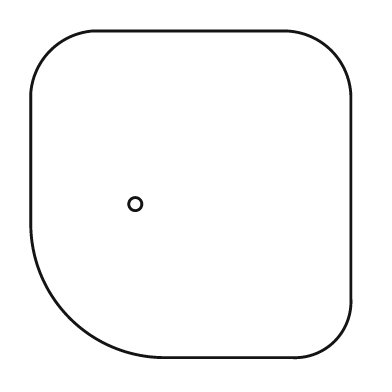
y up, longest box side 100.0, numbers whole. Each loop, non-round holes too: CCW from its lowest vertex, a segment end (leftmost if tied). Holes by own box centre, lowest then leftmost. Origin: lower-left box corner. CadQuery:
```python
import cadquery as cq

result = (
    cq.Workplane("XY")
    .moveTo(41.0, 0.0)
    .lineTo(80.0, 0.0)
    .threePointArc((93.0, 5.0), (98.0, 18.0))
    .lineTo(98.0, 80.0)
    .threePointArc((92.0, 94.0), (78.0, 100.0))
    .lineTo(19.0, 100.0)
    .threePointArc((6.0, 94.0), (0.0, 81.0))
    .lineTo(0.0, 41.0)
    .threePointArc((12.0, 12.0), (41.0, 0.0))
    .close()
    .moveTo(32.0, 47.0)
    .circle(2.0)
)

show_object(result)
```